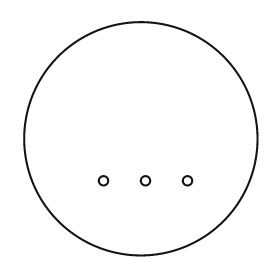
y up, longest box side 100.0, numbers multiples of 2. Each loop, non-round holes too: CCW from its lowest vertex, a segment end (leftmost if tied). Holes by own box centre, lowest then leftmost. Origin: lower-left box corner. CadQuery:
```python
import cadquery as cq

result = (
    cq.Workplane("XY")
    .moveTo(50.0, 50.0)
    .circle(50.0)
    .moveTo(34.0, 32.0)
    .circle(2.0)
    .moveTo(52.0, 32.0)
    .circle(2.0)
    .moveTo(70.0, 32.0)
    .circle(2.0)
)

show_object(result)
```